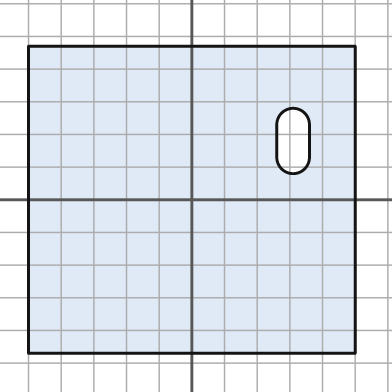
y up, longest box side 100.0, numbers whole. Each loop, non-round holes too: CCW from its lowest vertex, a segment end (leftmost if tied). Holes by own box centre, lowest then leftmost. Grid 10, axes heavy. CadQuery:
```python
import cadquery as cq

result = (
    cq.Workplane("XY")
    .moveTo(-50.0, -47.0)
    .lineTo(50.0, -47.0)
    .lineTo(50.0, 47.0)
    .lineTo(-50.0, 47.0)
    .close()
    .moveTo(26.0, 13.0)
    .threePointArc((31.0, 8.0), (36.0, 13.0))
    .lineTo(36.0, 23.0)
    .threePointArc((31.0, 28.0), (26.0, 23.0))
    .close()
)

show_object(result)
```